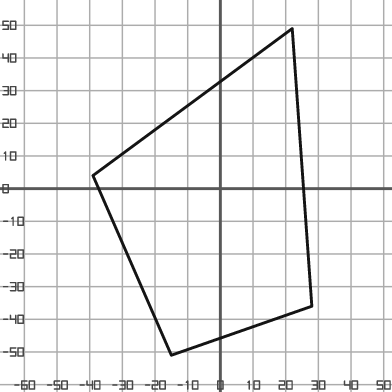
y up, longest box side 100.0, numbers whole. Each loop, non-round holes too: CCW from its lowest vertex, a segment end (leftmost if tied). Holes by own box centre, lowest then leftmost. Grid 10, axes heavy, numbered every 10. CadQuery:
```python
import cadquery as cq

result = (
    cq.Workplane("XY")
    .moveTo(-15.0, -51.0)
    .lineTo(28.0, -36.0)
    .lineTo(22.0, 49.0)
    .lineTo(-39.0, 4.0)
    .close()
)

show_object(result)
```